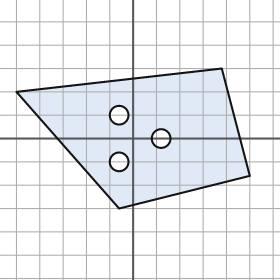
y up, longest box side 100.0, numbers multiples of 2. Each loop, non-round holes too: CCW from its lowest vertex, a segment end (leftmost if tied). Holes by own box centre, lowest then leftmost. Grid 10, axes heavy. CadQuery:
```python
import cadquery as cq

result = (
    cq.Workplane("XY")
    .moveTo(-6.0, -30.0)
    .lineTo(50.0, -16.0)
    .lineTo(38.0, 30.0)
    .lineTo(-50.0, 20.0)
    .close()
    .moveTo(-6.0, -10.0)
    .circle(4.0)
    .moveTo(12.0, 0.0)
    .circle(4.0)
    .moveTo(-6.0, 10.0)
    .circle(4.0)
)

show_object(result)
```